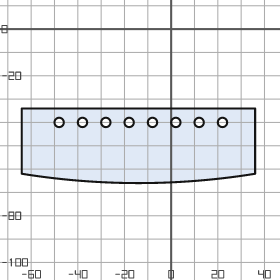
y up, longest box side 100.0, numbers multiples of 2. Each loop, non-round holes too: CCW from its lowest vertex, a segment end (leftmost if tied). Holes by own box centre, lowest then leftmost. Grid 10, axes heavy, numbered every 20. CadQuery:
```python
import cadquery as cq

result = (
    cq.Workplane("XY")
    .moveTo(-64.0, -62.0)
    .threePointArc((-14.0, -66.0), (36.0, -62.0))
    .lineTo(36.0, -34.0)
    .lineTo(-64.0, -34.0)
    .close()
    .moveTo(-48.0, -40.0)
    .circle(2.0)
    .moveTo(-38.0, -40.0)
    .circle(2.0)
    .moveTo(-28.0, -40.0)
    .circle(2.0)
    .moveTo(-18.0, -40.0)
    .circle(2.0)
    .moveTo(-8.0, -40.0)
    .circle(2.0)
    .moveTo(2.0, -40.0)
    .circle(2.0)
    .moveTo(12.0, -40.0)
    .circle(2.0)
    .moveTo(22.0, -40.0)
    .circle(2.0)
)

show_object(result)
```